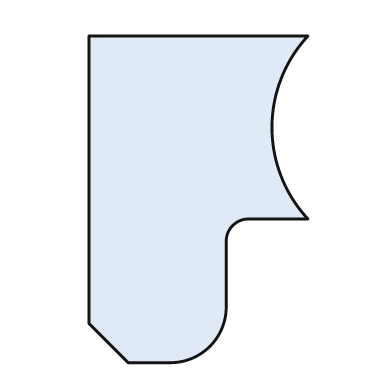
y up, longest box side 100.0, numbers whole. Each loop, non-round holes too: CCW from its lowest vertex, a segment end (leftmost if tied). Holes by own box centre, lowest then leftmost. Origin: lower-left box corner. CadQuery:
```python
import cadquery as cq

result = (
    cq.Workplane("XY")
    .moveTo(12.0, 0.0)
    .lineTo(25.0, 0.0)
    .threePointArc((37.0, 5.0), (42.0, 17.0))
    .lineTo(42.0, 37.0)
    .threePointArc((44.0, 42.0), (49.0, 44.0))
    .lineTo(67.0, 44.0)
    .threePointArc((56.0, 72.0), (67.0, 100.0))
    .lineTo(0.0, 100.0)
    .lineTo(0.0, 12.0)
    .close()
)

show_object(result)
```